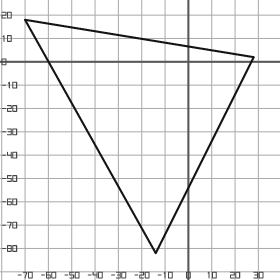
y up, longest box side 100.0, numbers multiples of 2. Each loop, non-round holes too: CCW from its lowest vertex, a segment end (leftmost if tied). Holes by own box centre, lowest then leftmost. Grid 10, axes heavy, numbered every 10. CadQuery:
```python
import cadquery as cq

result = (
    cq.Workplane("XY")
    .moveTo(-14.0, -82.0)
    .lineTo(28.0, 2.0)
    .lineTo(-70.0, 18.0)
    .close()
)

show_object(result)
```